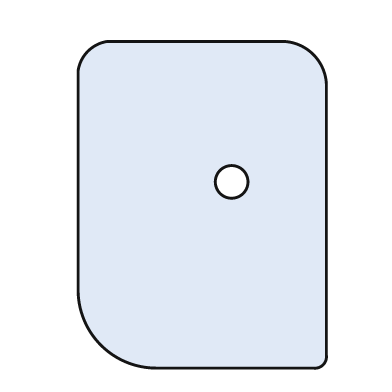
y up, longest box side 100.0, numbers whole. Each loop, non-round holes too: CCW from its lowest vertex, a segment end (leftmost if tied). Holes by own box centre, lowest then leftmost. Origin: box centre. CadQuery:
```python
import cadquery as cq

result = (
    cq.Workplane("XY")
    .moveTo(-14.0, -50.0)
    .lineTo(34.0, -50.0)
    .threePointArc((37.0, -49.0), (38.0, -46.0))
    .lineTo(38.0, 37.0)
    .threePointArc((34.0, 46.0), (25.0, 50.0))
    .lineTo(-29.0, 50.0)
    .threePointArc((-35.0, 47.0), (-38.0, 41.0))
    .lineTo(-38.0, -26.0)
    .threePointArc((-31.0, -43.0), (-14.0, -50.0))
    .close()
    .moveTo(9.0, 7.0)
    .circle(5.0)
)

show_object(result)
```